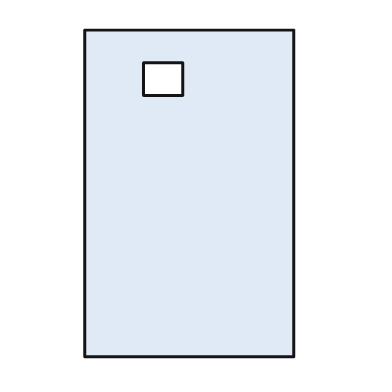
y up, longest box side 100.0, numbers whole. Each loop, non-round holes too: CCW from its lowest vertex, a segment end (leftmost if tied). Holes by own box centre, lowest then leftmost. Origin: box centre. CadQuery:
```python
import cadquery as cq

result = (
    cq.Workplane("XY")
    .moveTo(-32.0, -50.0)
    .lineTo(32.0, -50.0)
    .lineTo(32.0, 50.0)
    .lineTo(-32.0, 50.0)
    .close()
    .moveTo(-14.0, 30.0)
    .lineTo(-2.0, 30.0)
    .lineTo(-2.0, 40.0)
    .lineTo(-14.0, 40.0)
    .close()
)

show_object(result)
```